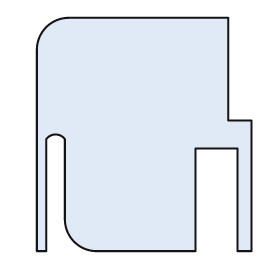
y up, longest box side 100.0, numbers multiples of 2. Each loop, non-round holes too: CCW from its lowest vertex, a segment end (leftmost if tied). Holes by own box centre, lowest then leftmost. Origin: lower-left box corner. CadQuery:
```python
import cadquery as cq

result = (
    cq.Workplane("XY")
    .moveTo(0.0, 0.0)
    .lineTo(4.0, 0.0)
    .lineTo(4.0, 48.0)
    .threePointArc((8.0, 50.0), (12.0, 48.0))
    .lineTo(12.0, 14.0)
    .threePointArc((16.0, 4.0), (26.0, 0.0))
    .lineTo(68.0, 0.0)
    .lineTo(68.0, 44.0)
    .lineTo(86.0, 44.0)
    .lineTo(86.0, 0.0)
    .lineTo(92.0, 0.0)
    .lineTo(92.0, 56.0)
    .lineTo(82.0, 56.0)
    .lineTo(82.0, 100.0)
    .lineTo(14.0, 100.0)
    .threePointArc((4.0, 96.0), (0.0, 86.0))
    .close()
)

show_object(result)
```